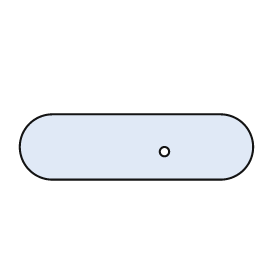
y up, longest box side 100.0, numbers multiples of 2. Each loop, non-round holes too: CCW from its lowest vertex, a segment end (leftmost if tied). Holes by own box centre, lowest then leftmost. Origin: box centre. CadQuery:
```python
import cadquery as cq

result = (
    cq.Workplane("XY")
    .moveTo(-36.0, -14.0)
    .lineTo(36.0, -14.0)
    .threePointArc((50.0, 0.0), (36.0, 14.0))
    .lineTo(-36.0, 14.0)
    .threePointArc((-50.0, 0.0), (-36.0, -14.0))
    .close()
    .moveTo(12.0, -2.0)
    .circle(2.0)
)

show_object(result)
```